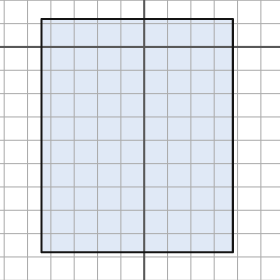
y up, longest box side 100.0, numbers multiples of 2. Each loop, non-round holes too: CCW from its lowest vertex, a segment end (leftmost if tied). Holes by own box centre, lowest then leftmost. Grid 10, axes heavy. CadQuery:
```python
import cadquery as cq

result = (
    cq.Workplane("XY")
    .moveTo(-44.0, -88.0)
    .lineTo(38.0, -88.0)
    .lineTo(38.0, 12.0)
    .lineTo(-44.0, 12.0)
    .close()
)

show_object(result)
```